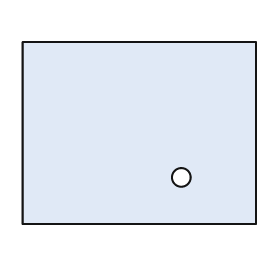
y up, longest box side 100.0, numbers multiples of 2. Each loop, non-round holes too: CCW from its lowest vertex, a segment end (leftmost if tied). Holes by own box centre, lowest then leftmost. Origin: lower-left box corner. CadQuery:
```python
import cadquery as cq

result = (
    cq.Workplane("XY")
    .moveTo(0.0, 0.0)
    .lineTo(100.0, 0.0)
    .lineTo(100.0, 78.0)
    .lineTo(0.0, 78.0)
    .close()
    .moveTo(68.0, 20.0)
    .circle(4.0)
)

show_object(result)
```